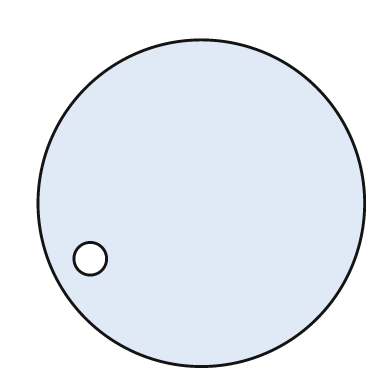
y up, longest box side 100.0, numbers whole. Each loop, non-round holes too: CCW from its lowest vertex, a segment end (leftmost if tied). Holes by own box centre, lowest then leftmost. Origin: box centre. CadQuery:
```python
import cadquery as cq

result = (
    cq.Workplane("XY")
    .moveTo(0.0, 0.0)
    .circle(50.0)
    .moveTo(-34.0, -17.0)
    .circle(5.0)
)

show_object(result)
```